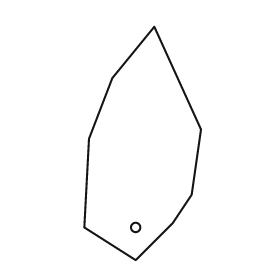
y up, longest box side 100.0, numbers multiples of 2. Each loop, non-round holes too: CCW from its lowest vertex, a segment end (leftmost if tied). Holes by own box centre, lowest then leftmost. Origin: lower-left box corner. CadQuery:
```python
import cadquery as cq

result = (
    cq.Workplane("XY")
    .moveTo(22.0, 0.0)
    .lineTo(38.0, 16.0)
    .lineTo(46.0, 28.0)
    .lineTo(50.0, 56.0)
    .lineTo(30.0, 100.0)
    .lineTo(12.0, 78.0)
    .lineTo(2.0, 52.0)
    .lineTo(0.0, 14.0)
    .close()
    .moveTo(22.0, 14.0)
    .circle(2.0)
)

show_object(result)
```